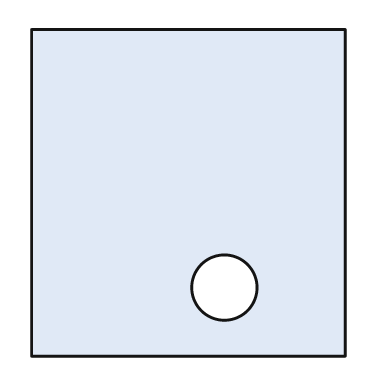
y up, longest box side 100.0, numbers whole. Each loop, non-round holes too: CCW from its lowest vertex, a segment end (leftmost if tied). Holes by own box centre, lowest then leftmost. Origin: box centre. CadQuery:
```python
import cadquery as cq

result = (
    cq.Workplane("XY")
    .moveTo(-48.0, -50.0)
    .lineTo(48.0, -50.0)
    .lineTo(48.0, 50.0)
    .lineTo(-48.0, 50.0)
    .close()
    .moveTo(11.0, -29.0)
    .circle(10.0)
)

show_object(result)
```